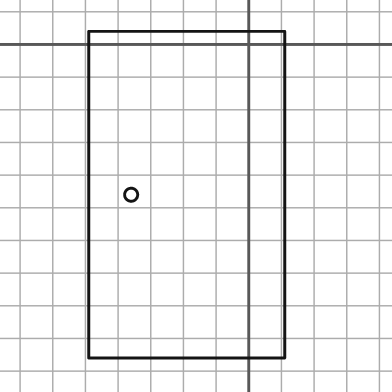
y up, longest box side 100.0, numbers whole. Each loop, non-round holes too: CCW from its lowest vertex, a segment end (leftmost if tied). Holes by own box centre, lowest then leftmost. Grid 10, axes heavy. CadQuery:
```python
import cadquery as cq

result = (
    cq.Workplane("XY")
    .moveTo(-49.0, -96.0)
    .lineTo(11.0, -96.0)
    .lineTo(11.0, 4.0)
    .lineTo(-49.0, 4.0)
    .close()
    .moveTo(-36.0, -46.0)
    .circle(2.0)
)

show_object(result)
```